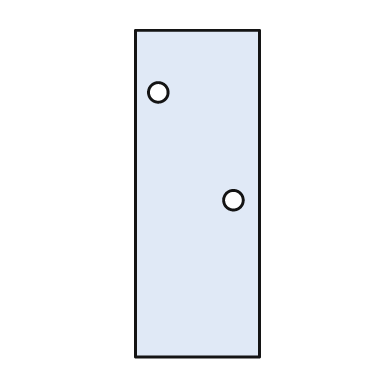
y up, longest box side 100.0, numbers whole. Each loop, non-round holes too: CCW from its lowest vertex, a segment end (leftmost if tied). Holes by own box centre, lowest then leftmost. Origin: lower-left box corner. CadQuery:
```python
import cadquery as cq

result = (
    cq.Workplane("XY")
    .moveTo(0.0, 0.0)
    .lineTo(38.0, 0.0)
    .lineTo(38.0, 100.0)
    .lineTo(0.0, 100.0)
    .close()
    .moveTo(30.0, 48.0)
    .circle(3.0)
    .moveTo(7.0, 81.0)
    .circle(3.0)
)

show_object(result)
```